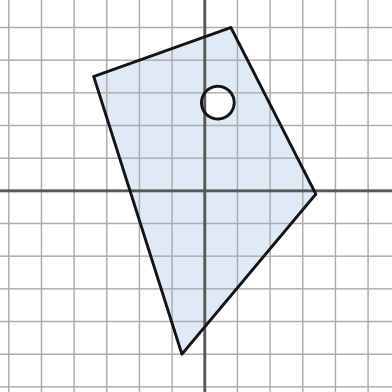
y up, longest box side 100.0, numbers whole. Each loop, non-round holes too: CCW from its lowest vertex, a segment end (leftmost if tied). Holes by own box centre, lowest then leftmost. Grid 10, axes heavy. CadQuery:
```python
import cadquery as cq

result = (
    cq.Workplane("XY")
    .moveTo(-7.0, -50.0)
    .lineTo(34.0, -1.0)
    .lineTo(8.0, 50.0)
    .lineTo(-34.0, 35.0)
    .close()
    .moveTo(4.0, 27.0)
    .circle(5.0)
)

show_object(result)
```